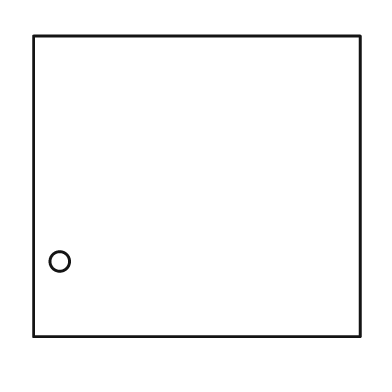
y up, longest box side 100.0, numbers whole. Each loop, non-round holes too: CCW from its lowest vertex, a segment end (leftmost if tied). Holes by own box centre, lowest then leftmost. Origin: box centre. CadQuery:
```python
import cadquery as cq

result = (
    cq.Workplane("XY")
    .moveTo(-50.0, -46.0)
    .lineTo(50.0, -46.0)
    .lineTo(50.0, 46.0)
    .lineTo(-50.0, 46.0)
    .close()
    .moveTo(-42.0, -23.0)
    .circle(3.0)
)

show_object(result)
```